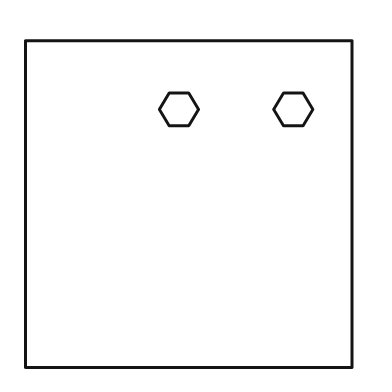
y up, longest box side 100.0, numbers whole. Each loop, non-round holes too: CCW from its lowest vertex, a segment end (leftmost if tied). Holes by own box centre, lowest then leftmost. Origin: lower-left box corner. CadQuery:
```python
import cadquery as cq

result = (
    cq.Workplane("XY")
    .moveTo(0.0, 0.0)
    .lineTo(100.0, 0.0)
    .lineTo(100.0, 100.0)
    .lineTo(0.0, 100.0)
    .close()
    .moveTo(44.0, 74.0)
    .lineTo(50.0, 74.0)
    .lineTo(53.0, 79.0)
    .lineTo(50.0, 84.0)
    .lineTo(44.0, 84.0)
    .lineTo(41.0, 79.0)
    .close()
    .moveTo(79.0, 74.0)
    .lineTo(85.0, 74.0)
    .lineTo(88.0, 79.0)
    .lineTo(85.0, 84.0)
    .lineTo(79.0, 84.0)
    .lineTo(76.0, 79.0)
    .close()
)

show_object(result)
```